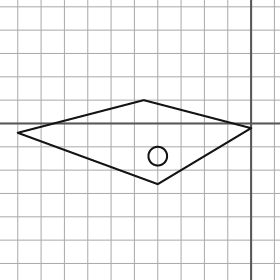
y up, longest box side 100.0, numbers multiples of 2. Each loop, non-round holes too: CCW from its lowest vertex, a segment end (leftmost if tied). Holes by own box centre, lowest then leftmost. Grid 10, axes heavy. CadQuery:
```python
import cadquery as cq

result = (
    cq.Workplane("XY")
    .moveTo(-40.0, -26.0)
    .lineTo(0.0, -2.0)
    .lineTo(-46.0, 10.0)
    .lineTo(-100.0, -4.0)
    .close()
    .moveTo(-40.0, -14.0)
    .circle(4.0)
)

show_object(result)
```